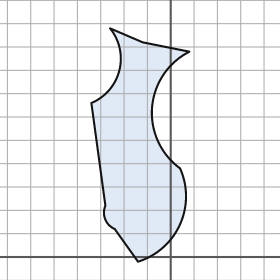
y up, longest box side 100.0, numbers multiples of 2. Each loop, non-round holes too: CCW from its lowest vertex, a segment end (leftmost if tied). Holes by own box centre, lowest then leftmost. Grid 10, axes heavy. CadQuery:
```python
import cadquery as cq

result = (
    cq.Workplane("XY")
    .moveTo(-14.0, -2.0)
    .threePointArc((4.0, 14.0), (4.0, 38.0))
    .threePointArc((-8.0, 64.0), (8.0, 88.0))
    .lineTo(-12.0, 92.0)
    .lineTo(-26.0, 98.0)
    .threePointArc((-22.0, 80.0), (-34.0, 66.0))
    .lineTo(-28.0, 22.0)
    .threePointArc((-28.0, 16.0), (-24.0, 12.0))
    .close()
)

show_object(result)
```